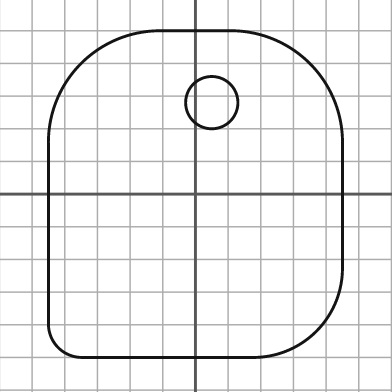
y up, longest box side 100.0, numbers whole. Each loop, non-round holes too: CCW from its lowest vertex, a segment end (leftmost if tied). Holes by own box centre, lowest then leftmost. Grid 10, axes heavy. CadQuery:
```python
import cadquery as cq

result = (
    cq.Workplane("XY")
    .moveTo(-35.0, -50.0)
    .lineTo(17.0, -50.0)
    .threePointArc((37.0, -42.0), (45.0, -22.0))
    .lineTo(45.0, 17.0)
    .threePointArc((35.0, 40.0), (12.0, 50.0))
    .lineTo(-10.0, 50.0)
    .threePointArc((-35.0, 40.0), (-45.0, 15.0))
    .lineTo(-45.0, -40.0)
    .threePointArc((-42.0, -47.0), (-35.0, -50.0))
    .close()
    .moveTo(5.0, 28.0)
    .circle(8.0)
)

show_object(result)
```